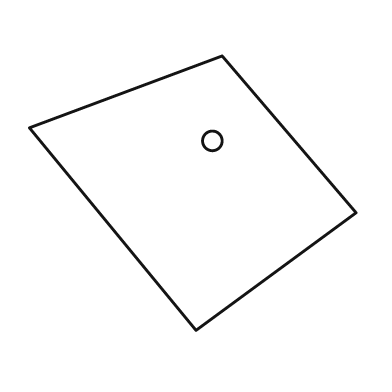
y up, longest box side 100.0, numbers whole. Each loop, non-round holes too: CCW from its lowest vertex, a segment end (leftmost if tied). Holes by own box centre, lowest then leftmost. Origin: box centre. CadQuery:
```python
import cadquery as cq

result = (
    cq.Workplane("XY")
    .moveTo(1.0, -42.0)
    .lineTo(50.0, -6.0)
    .lineTo(9.0, 42.0)
    .lineTo(-50.0, 20.0)
    .close()
    .moveTo(6.0, 16.0)
    .circle(3.0)
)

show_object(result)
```